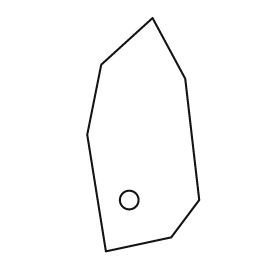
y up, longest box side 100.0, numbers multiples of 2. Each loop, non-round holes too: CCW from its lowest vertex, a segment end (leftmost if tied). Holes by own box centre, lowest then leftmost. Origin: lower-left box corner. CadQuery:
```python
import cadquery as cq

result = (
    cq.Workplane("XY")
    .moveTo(8.0, 0.0)
    .lineTo(36.0, 6.0)
    .lineTo(48.0, 22.0)
    .lineTo(42.0, 74.0)
    .lineTo(28.0, 100.0)
    .lineTo(6.0, 80.0)
    .lineTo(0.0, 50.0)
    .close()
    .moveTo(18.0, 22.0)
    .circle(4.0)
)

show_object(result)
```